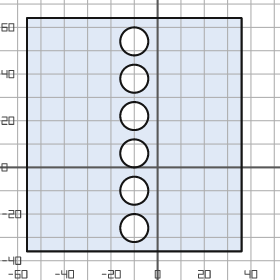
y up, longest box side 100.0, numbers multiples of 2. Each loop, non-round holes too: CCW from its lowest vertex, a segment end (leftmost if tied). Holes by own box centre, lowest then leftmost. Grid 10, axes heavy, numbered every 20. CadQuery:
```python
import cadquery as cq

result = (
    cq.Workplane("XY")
    .moveTo(-56.0, -36.0)
    .lineTo(36.0, -36.0)
    .lineTo(36.0, 64.0)
    .lineTo(-56.0, 64.0)
    .close()
    .moveTo(-10.0, -26.0)
    .circle(6.0)
    .moveTo(-10.0, -10.0)
    .circle(6.0)
    .moveTo(-10.0, 6.0)
    .circle(6.0)
    .moveTo(-10.0, 22.0)
    .circle(6.0)
    .moveTo(-10.0, 38.0)
    .circle(6.0)
    .moveTo(-10.0, 54.0)
    .circle(6.0)
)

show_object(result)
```